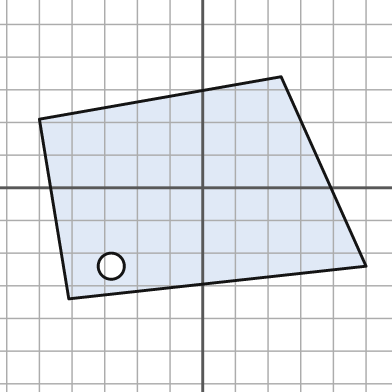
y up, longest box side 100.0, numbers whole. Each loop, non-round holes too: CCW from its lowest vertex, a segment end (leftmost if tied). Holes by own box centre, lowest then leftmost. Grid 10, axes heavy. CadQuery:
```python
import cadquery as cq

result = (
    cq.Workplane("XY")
    .moveTo(-41.0, -34.0)
    .lineTo(50.0, -24.0)
    .lineTo(24.0, 34.0)
    .lineTo(-50.0, 21.0)
    .close()
    .moveTo(-28.0, -24.0)
    .circle(4.0)
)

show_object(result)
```